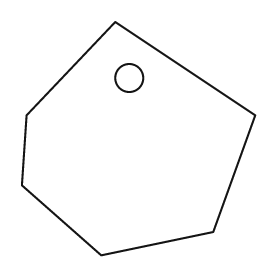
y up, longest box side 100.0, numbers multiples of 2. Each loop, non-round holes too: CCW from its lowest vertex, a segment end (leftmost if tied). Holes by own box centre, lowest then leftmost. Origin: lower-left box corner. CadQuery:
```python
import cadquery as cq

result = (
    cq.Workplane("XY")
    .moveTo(34.0, 0.0)
    .lineTo(82.0, 10.0)
    .lineTo(100.0, 60.0)
    .lineTo(40.0, 100.0)
    .lineTo(2.0, 60.0)
    .lineTo(0.0, 30.0)
    .close()
    .moveTo(46.0, 76.0)
    .circle(6.0)
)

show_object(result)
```